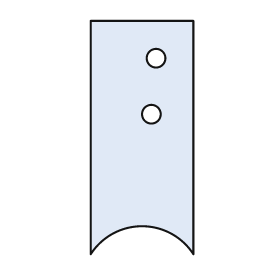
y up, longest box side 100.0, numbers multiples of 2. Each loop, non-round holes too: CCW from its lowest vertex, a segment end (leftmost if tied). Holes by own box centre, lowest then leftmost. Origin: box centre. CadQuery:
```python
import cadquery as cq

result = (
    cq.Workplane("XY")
    .moveTo(-22.0, -50.0)
    .threePointArc((0.0, -38.0), (22.0, -50.0))
    .lineTo(22.0, 50.0)
    .lineTo(-22.0, 50.0)
    .close()
    .moveTo(4.0, 10.0)
    .circle(4.0)
    .moveTo(6.0, 34.0)
    .circle(4.0)
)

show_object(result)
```